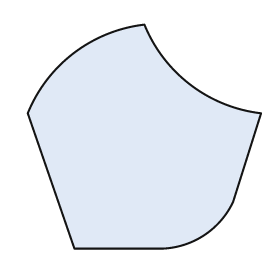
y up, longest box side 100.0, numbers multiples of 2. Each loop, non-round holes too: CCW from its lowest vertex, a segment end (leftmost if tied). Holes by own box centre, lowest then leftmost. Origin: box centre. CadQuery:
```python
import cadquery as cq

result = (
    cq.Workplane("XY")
    .moveTo(-30.0, -48.0)
    .lineTo(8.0, -48.0)
    .threePointArc((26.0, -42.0), (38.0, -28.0))
    .lineTo(50.0, 10.0)
    .threePointArc((20.0, 22.0), (0.0, 48.0))
    .threePointArc((-30.0, 36.0), (-50.0, 10.0))
    .close()
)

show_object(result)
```